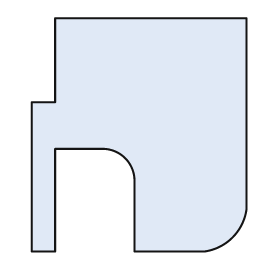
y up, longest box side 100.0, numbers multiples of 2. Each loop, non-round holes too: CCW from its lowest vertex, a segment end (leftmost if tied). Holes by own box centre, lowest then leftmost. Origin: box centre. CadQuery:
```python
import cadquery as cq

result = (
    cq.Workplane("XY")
    .moveTo(-46.0, -50.0)
    .lineTo(-36.0, -50.0)
    .lineTo(-36.0, -6.0)
    .lineTo(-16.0, -6.0)
    .threePointArc((-6.0, -10.0), (-2.0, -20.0))
    .lineTo(-2.0, -50.0)
    .lineTo(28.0, -50.0)
    .threePointArc((40.0, -44.0), (46.0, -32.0))
    .lineTo(46.0, 50.0)
    .lineTo(-36.0, 50.0)
    .lineTo(-36.0, 14.0)
    .lineTo(-46.0, 14.0)
    .close()
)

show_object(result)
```